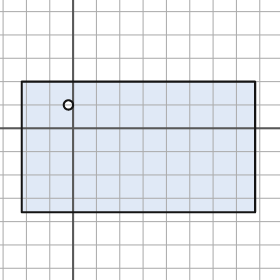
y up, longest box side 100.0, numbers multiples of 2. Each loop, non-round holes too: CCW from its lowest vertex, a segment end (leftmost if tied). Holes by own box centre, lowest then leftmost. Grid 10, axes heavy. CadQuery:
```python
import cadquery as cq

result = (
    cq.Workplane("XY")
    .moveTo(-22.0, -36.0)
    .lineTo(78.0, -36.0)
    .lineTo(78.0, 20.0)
    .lineTo(-22.0, 20.0)
    .close()
    .moveTo(-2.0, 10.0)
    .circle(2.0)
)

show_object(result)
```